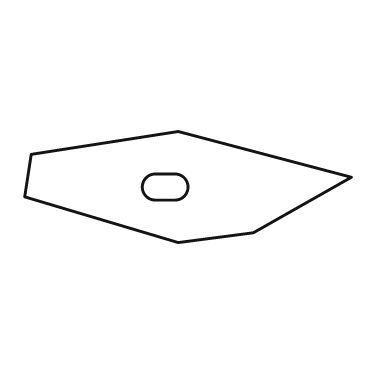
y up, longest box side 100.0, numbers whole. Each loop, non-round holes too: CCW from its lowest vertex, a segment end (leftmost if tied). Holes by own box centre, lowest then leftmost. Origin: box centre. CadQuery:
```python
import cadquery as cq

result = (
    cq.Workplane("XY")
    .moveTo(-3.0, -17.0)
    .lineTo(20.0, -14.0)
    .lineTo(50.0, 3.0)
    .lineTo(-3.0, 17.0)
    .lineTo(-48.0, 10.0)
    .lineTo(-50.0, -3.0)
    .close()
    .moveTo(-10.0, -4.0)
    .lineTo(-4.0, -4.0)
    .threePointArc((0.0, 0.0), (-4.0, 4.0))
    .lineTo(-10.0, 4.0)
    .threePointArc((-14.0, 0.0), (-10.0, -4.0))
    .close()
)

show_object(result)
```